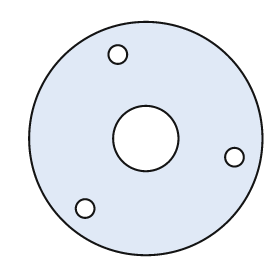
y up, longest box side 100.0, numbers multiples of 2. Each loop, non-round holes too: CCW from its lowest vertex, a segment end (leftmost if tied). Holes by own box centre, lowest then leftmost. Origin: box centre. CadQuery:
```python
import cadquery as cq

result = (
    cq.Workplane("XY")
    .moveTo(0.0, 0.0)
    .circle(50.0)
    .moveTo(-26.0, -30.0)
    .circle(4.0)
    .moveTo(38.0, -8.0)
    .circle(4.0)
    .moveTo(0.0, 0.0)
    .circle(14.0)
    .moveTo(-12.0, 36.0)
    .circle(4.0)
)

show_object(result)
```